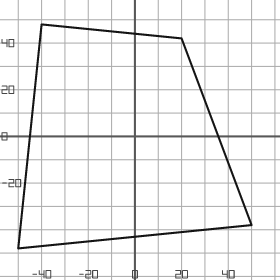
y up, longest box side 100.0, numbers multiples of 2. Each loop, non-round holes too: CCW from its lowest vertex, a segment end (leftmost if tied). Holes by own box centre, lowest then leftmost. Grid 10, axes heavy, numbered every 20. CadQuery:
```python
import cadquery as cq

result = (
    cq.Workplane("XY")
    .moveTo(-50.0, -48.0)
    .lineTo(50.0, -38.0)
    .lineTo(20.0, 42.0)
    .lineTo(-40.0, 48.0)
    .close()
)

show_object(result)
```